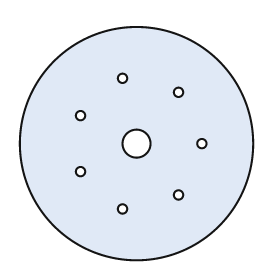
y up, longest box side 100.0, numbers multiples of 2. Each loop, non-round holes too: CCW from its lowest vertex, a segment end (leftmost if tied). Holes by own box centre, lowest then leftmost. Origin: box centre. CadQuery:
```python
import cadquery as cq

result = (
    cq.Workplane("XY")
    .moveTo(0.0, 0.0)
    .circle(50.0)
    .moveTo(-6.0, -28.0)
    .circle(2.0)
    .moveTo(18.0, -22.0)
    .circle(2.0)
    .moveTo(-24.0, -12.0)
    .circle(2.0)
    .moveTo(0.0, 0.0)
    .circle(6.0)
    .moveTo(28.0, 0.0)
    .circle(2.0)
    .moveTo(-24.0, 12.0)
    .circle(2.0)
    .moveTo(18.0, 22.0)
    .circle(2.0)
    .moveTo(-6.0, 28.0)
    .circle(2.0)
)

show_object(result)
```